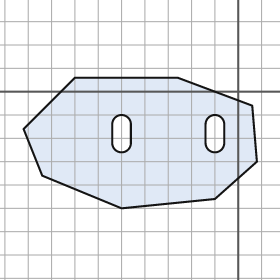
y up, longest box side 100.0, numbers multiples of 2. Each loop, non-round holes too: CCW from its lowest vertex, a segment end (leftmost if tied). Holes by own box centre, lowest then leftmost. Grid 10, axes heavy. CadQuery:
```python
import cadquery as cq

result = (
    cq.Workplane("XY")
    .moveTo(-50.0, -50.0)
    .lineTo(-10.0, -46.0)
    .lineTo(8.0, -30.0)
    .lineTo(6.0, -6.0)
    .lineTo(-26.0, 6.0)
    .lineTo(-70.0, 6.0)
    .lineTo(-92.0, -16.0)
    .lineTo(-84.0, -36.0)
    .close()
    .moveTo(-54.0, -22.0)
    .threePointArc((-50.0, -26.0), (-46.0, -22.0))
    .lineTo(-46.0, -14.0)
    .threePointArc((-50.0, -10.0), (-54.0, -14.0))
    .close()
    .moveTo(-14.0, -22.0)
    .threePointArc((-10.0, -26.0), (-6.0, -22.0))
    .lineTo(-6.0, -14.0)
    .threePointArc((-10.0, -10.0), (-14.0, -14.0))
    .close()
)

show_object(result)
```